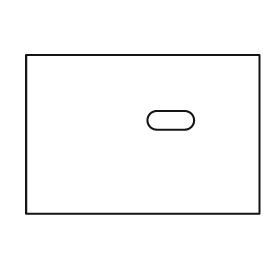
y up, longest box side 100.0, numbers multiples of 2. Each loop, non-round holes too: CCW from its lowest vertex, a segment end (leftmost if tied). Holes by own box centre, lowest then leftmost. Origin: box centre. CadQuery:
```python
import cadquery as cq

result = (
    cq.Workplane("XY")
    .moveTo(-50.0, -34.0)
    .lineTo(50.0, -34.0)
    .lineTo(50.0, 34.0)
    .lineTo(-50.0, 34.0)
    .close()
    .moveTo(6.0, 2.0)
    .lineTo(18.0, 2.0)
    .threePointArc((22.0, 6.0), (18.0, 10.0))
    .lineTo(6.0, 10.0)
    .threePointArc((2.0, 6.0), (6.0, 2.0))
    .close()
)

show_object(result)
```